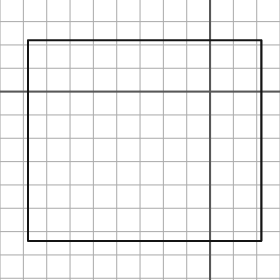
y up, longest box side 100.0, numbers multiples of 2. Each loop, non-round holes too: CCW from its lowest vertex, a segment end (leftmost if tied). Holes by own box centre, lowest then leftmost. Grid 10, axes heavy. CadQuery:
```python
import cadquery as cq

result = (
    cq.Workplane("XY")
    .moveTo(-78.0, -64.0)
    .lineTo(22.0, -64.0)
    .lineTo(22.0, 22.0)
    .lineTo(-78.0, 22.0)
    .close()
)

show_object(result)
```